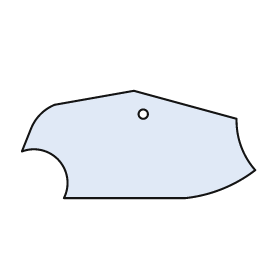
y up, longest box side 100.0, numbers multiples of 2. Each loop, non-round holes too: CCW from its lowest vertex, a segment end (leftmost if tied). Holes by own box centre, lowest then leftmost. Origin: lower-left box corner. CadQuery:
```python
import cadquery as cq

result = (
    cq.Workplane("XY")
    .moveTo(18.0, 0.0)
    .lineTo(70.0, 0.0)
    .threePointArc((86.0, 4.0), (100.0, 12.0))
    .threePointArc((94.0, 22.0), (92.0, 34.0))
    .lineTo(48.0, 46.0)
    .lineTo(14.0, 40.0)
    .threePointArc((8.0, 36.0), (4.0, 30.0))
    .lineTo(0.0, 20.0)
    .threePointArc((16.0, 16.0), (18.0, 0.0))
    .close()
    .moveTo(52.0, 36.0)
    .circle(2.0)
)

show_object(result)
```